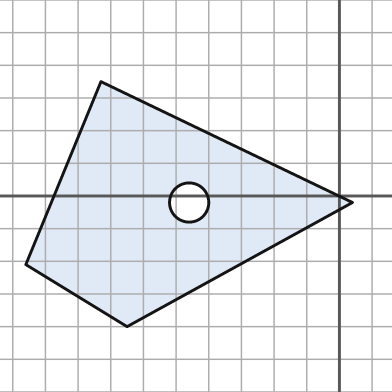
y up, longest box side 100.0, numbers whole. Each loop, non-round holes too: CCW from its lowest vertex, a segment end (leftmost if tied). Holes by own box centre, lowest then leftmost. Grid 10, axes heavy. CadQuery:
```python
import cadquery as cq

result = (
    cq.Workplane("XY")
    .moveTo(-65.0, -40.0)
    .lineTo(4.0, -2.0)
    .lineTo(-73.0, 35.0)
    .lineTo(-96.0, -21.0)
    .close()
    .moveTo(-46.0, -2.0)
    .circle(6.0)
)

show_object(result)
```